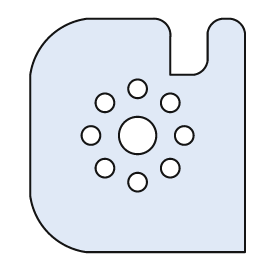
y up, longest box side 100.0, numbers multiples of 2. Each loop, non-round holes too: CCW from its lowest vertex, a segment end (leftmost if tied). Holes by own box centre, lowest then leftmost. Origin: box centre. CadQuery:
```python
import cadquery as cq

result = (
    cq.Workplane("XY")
    .moveTo(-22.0, -50.0)
    .lineTo(46.0, -50.0)
    .lineTo(46.0, 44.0)
    .threePointArc((44.0, 48.0), (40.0, 50.0))
    .lineTo(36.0, 50.0)
    .threePointArc((32.0, 48.0), (30.0, 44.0))
    .lineTo(30.0, 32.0)
    .threePointArc((28.0, 28.0), (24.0, 26.0))
    .lineTo(14.0, 26.0)
    .lineTo(14.0, 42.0)
    .threePointArc((12.0, 48.0), (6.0, 50.0))
    .lineTo(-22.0, 50.0)
    .threePointArc((-38.0, 42.0), (-46.0, 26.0))
    .lineTo(-46.0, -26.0)
    .threePointArc((-38.0, -42.0), (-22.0, -50.0))
    .close()
    .moveTo(0.0, -20.0)
    .circle(4.0)
    .moveTo(-14.0, -14.0)
    .circle(4.0)
    .moveTo(14.0, -14.0)
    .circle(4.0)
    .moveTo(-20.0, 0.0)
    .circle(4.0)
    .moveTo(0.0, 0.0)
    .circle(8.0)
    .moveTo(20.0, 0.0)
    .circle(4.0)
    .moveTo(-14.0, 14.0)
    .circle(4.0)
    .moveTo(14.0, 14.0)
    .circle(4.0)
    .moveTo(0.0, 20.0)
    .circle(4.0)
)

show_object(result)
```